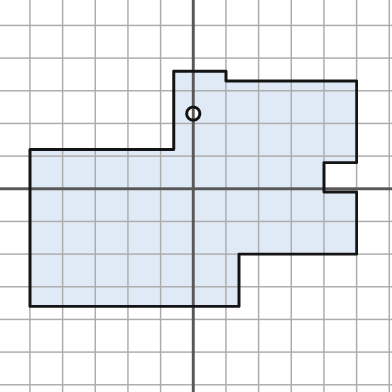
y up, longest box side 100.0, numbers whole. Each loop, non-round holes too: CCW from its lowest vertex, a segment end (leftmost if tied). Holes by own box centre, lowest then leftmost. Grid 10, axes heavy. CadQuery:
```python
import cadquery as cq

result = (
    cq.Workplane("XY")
    .moveTo(-50.0, -36.0)
    .lineTo(14.0, -36.0)
    .lineTo(14.0, -20.0)
    .lineTo(50.0, -20.0)
    .lineTo(50.0, -1.0)
    .lineTo(40.0, -1.0)
    .lineTo(40.0, 8.0)
    .lineTo(50.0, 8.0)
    .lineTo(50.0, 33.0)
    .lineTo(10.0, 33.0)
    .lineTo(10.0, 36.0)
    .lineTo(-6.0, 36.0)
    .lineTo(-6.0, 12.0)
    .lineTo(-50.0, 12.0)
    .close()
    .moveTo(0.0, 23.0)
    .circle(2.0)
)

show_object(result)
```